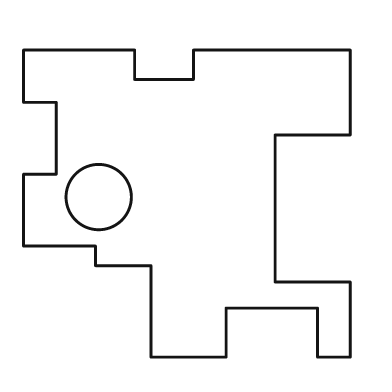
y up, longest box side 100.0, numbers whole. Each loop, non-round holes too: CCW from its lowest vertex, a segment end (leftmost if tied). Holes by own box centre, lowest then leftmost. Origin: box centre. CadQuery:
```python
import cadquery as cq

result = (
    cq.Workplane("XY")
    .moveTo(-11.0, -47.0)
    .lineTo(12.0, -47.0)
    .lineTo(12.0, -32.0)
    .lineTo(40.0, -32.0)
    .lineTo(40.0, -47.0)
    .lineTo(50.0, -47.0)
    .lineTo(50.0, -24.0)
    .lineTo(27.0, -24.0)
    .lineTo(27.0, 21.0)
    .lineTo(50.0, 21.0)
    .lineTo(50.0, 47.0)
    .lineTo(2.0, 47.0)
    .lineTo(2.0, 38.0)
    .lineTo(-16.0, 38.0)
    .lineTo(-16.0, 47.0)
    .lineTo(-50.0, 47.0)
    .lineTo(-50.0, 31.0)
    .lineTo(-40.0, 31.0)
    .lineTo(-40.0, 9.0)
    .lineTo(-50.0, 9.0)
    .lineTo(-50.0, -13.0)
    .lineTo(-28.0, -13.0)
    .lineTo(-28.0, -19.0)
    .lineTo(-11.0, -19.0)
    .close()
    .moveTo(-27.0, 2.0)
    .circle(10.0)
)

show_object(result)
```